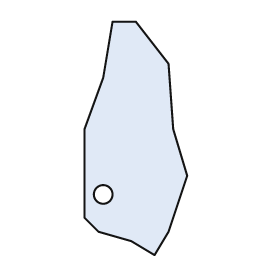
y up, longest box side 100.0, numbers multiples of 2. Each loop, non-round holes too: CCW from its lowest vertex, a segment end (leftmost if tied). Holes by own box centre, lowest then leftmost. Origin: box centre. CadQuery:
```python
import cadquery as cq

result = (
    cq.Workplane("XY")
    .moveTo(8.0, -50.0)
    .lineTo(14.0, -40.0)
    .lineTo(22.0, -16.0)
    .lineTo(16.0, 4.0)
    .lineTo(14.0, 32.0)
    .lineTo(0.0, 50.0)
    .lineTo(-10.0, 50.0)
    .lineTo(-14.0, 26.0)
    .lineTo(-22.0, 4.0)
    .lineTo(-22.0, -34.0)
    .lineTo(-16.0, -40.0)
    .lineTo(-2.0, -44.0)
    .close()
    .moveTo(-14.0, -24.0)
    .circle(4.0)
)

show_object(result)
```